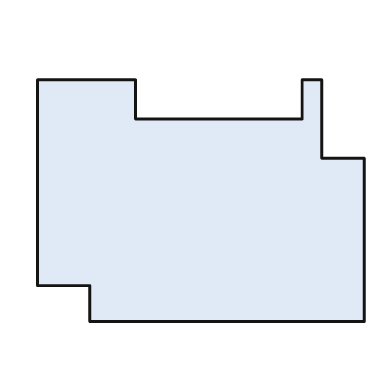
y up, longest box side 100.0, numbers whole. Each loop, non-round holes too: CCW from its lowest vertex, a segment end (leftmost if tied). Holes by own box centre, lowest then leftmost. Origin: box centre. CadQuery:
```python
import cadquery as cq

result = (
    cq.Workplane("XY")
    .moveTo(-34.0, -37.0)
    .lineTo(50.0, -37.0)
    .lineTo(50.0, 13.0)
    .lineTo(37.0, 13.0)
    .lineTo(37.0, 37.0)
    .lineTo(31.0, 37.0)
    .lineTo(31.0, 25.0)
    .lineTo(-20.0, 25.0)
    .lineTo(-20.0, 37.0)
    .lineTo(-50.0, 37.0)
    .lineTo(-50.0, -26.0)
    .lineTo(-34.0, -26.0)
    .close()
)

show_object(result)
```